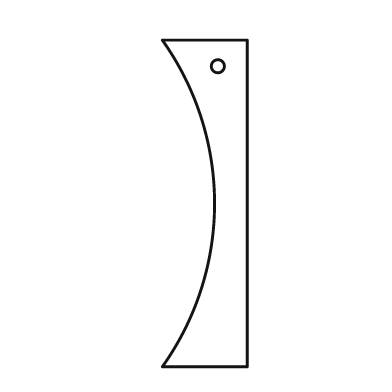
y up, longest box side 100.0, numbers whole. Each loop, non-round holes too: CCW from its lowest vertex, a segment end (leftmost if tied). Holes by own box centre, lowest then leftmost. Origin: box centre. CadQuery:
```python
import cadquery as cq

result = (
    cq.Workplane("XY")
    .moveTo(-13.0, -50.0)
    .lineTo(13.0, -50.0)
    .lineTo(13.0, 50.0)
    .lineTo(-13.0, 50.0)
    .threePointArc((3.0, 0.0), (-13.0, -50.0))
    .close()
    .moveTo(4.0, 42.0)
    .circle(2.0)
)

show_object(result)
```